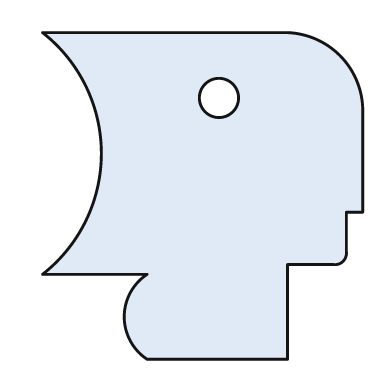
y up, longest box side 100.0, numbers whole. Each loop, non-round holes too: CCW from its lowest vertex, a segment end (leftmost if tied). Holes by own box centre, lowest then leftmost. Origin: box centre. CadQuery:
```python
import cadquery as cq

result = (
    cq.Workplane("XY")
    .moveTo(-17.0, -50.0)
    .lineTo(26.0, -50.0)
    .lineTo(26.0, -21.0)
    .lineTo(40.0, -21.0)
    .threePointArc((43.0, -20.0), (44.0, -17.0))
    .lineTo(44.0, -5.0)
    .lineTo(49.0, -5.0)
    .lineTo(49.0, 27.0)
    .threePointArc((42.0, 43.0), (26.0, 50.0))
    .lineTo(-49.0, 50.0)
    .threePointArc((-31.0, 13.0), (-49.0, -24.0))
    .lineTo(-17.0, -24.0)
    .threePointArc((-24.0, -37.0), (-17.0, -50.0))
    .close()
    .moveTo(5.0, 30.0)
    .circle(6.0)
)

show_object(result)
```